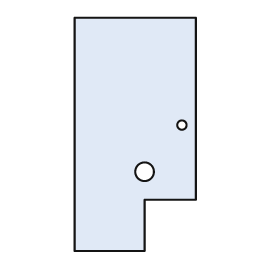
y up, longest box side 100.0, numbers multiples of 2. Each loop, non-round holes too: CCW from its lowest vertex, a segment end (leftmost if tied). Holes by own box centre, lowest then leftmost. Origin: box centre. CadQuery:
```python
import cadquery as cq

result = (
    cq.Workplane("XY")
    .moveTo(-26.0, -50.0)
    .lineTo(4.0, -50.0)
    .lineTo(4.0, -28.0)
    .lineTo(26.0, -28.0)
    .lineTo(26.0, 50.0)
    .lineTo(-26.0, 50.0)
    .close()
    .moveTo(4.0, -16.0)
    .circle(4.0)
    .moveTo(20.0, 4.0)
    .circle(2.0)
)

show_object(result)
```